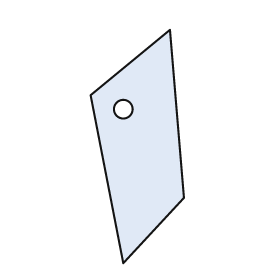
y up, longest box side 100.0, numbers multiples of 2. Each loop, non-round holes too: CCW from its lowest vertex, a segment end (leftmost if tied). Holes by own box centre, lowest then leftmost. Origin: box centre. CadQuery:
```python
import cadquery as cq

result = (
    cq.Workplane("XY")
    .moveTo(-6.0, -50.0)
    .lineTo(20.0, -22.0)
    .lineTo(14.0, 50.0)
    .lineTo(-20.0, 22.0)
    .close()
    .moveTo(-6.0, 16.0)
    .circle(4.0)
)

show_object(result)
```